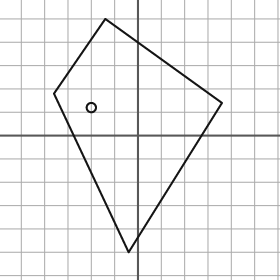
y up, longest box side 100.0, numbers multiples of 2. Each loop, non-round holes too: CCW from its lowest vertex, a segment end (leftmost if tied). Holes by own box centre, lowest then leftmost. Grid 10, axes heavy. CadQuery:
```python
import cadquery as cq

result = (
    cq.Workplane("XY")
    .moveTo(-4.0, -50.0)
    .lineTo(36.0, 14.0)
    .lineTo(-14.0, 50.0)
    .lineTo(-36.0, 18.0)
    .close()
    .moveTo(-20.0, 12.0)
    .circle(2.0)
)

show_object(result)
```